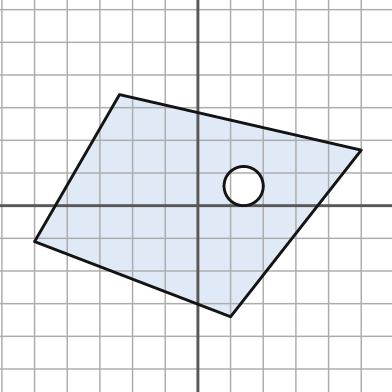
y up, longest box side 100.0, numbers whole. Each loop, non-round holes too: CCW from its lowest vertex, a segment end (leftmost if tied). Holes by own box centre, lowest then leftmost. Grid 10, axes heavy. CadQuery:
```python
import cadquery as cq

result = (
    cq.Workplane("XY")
    .moveTo(10.0, -34.0)
    .lineTo(50.0, 17.0)
    .lineTo(-24.0, 34.0)
    .lineTo(-50.0, -11.0)
    .close()
    .moveTo(14.0, 6.0)
    .circle(6.0)
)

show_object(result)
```